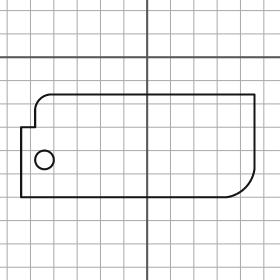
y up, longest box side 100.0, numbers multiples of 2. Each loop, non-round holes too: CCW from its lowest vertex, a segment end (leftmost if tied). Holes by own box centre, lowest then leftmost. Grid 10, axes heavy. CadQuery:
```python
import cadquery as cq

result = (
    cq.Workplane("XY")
    .moveTo(-54.0, -60.0)
    .lineTo(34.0, -60.0)
    .threePointArc((42.0, -56.0), (46.0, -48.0))
    .lineTo(46.0, -16.0)
    .lineTo(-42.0, -16.0)
    .threePointArc((-46.0, -18.0), (-48.0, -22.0))
    .lineTo(-48.0, -30.0)
    .lineTo(-54.0, -30.0)
    .close()
    .moveTo(-44.0, -44.0)
    .circle(4.0)
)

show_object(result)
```